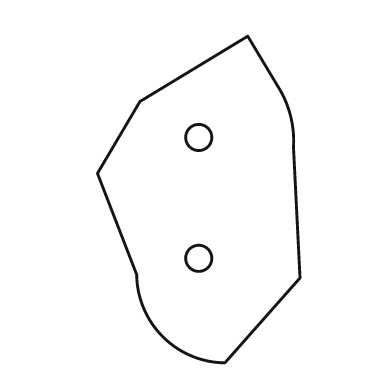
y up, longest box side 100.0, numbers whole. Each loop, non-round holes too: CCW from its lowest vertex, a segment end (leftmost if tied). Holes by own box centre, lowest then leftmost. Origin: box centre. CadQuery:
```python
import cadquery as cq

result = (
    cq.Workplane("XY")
    .moveTo(8.0, -50.0)
    .lineTo(31.0, -24.0)
    .lineTo(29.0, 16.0)
    .threePointArc((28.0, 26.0), (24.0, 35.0))
    .lineTo(15.0, 50.0)
    .lineTo(-18.0, 30.0)
    .lineTo(-31.0, 8.0)
    .lineTo(-19.0, -23.0)
    .threePointArc((-11.0, -42.0), (8.0, -50.0))
    .close()
    .moveTo(0.0, -18.0)
    .circle(4.0)
    .moveTo(0.0, 19.0)
    .circle(4.0)
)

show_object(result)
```